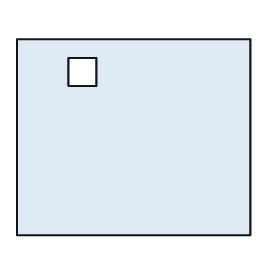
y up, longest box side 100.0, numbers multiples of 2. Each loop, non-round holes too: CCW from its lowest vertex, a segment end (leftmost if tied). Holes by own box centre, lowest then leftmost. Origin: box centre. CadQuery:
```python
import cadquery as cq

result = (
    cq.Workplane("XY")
    .moveTo(-50.0, -42.0)
    .lineTo(50.0, -42.0)
    .lineTo(50.0, 42.0)
    .lineTo(-50.0, 42.0)
    .close()
    .moveTo(-28.0, 22.0)
    .lineTo(-16.0, 22.0)
    .lineTo(-16.0, 34.0)
    .lineTo(-28.0, 34.0)
    .close()
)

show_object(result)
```